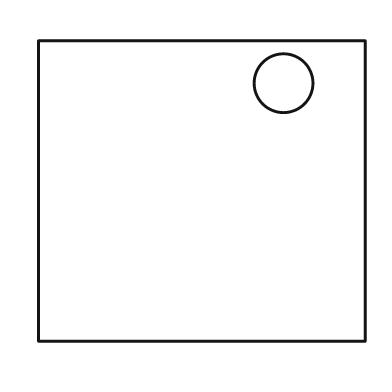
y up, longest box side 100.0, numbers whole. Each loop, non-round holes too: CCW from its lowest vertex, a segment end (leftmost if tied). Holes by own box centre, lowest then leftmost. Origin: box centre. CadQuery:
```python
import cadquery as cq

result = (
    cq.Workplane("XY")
    .moveTo(-50.0, -46.0)
    .lineTo(50.0, -46.0)
    .lineTo(50.0, 46.0)
    .lineTo(-50.0, 46.0)
    .close()
    .moveTo(25.0, 33.0)
    .circle(9.0)
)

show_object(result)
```